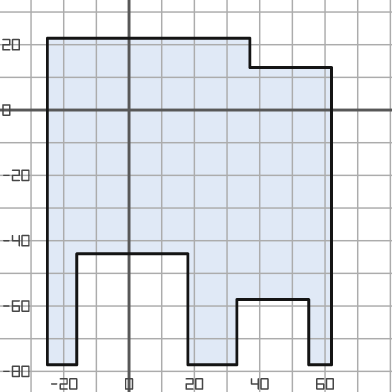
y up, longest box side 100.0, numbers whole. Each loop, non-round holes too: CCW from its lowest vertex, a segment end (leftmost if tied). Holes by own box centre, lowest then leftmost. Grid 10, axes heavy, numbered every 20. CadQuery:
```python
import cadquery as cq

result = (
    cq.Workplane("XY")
    .moveTo(-25.0, -78.0)
    .lineTo(-16.0, -78.0)
    .lineTo(-16.0, -44.0)
    .lineTo(18.0, -44.0)
    .lineTo(18.0, -78.0)
    .lineTo(33.0, -78.0)
    .lineTo(33.0, -58.0)
    .lineTo(55.0, -58.0)
    .lineTo(55.0, -78.0)
    .lineTo(62.0, -78.0)
    .lineTo(62.0, 13.0)
    .lineTo(37.0, 13.0)
    .lineTo(37.0, 22.0)
    .lineTo(-25.0, 22.0)
    .close()
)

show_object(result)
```